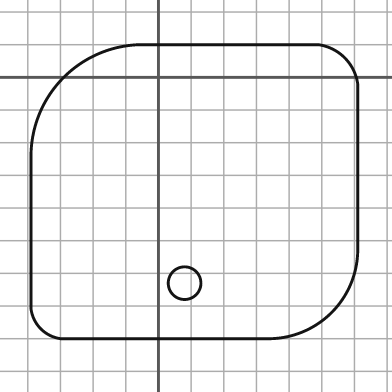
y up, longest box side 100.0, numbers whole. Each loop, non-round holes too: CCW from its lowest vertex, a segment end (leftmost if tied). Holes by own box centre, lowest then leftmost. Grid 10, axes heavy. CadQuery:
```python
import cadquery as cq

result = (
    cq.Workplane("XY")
    .moveTo(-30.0, -80.0)
    .lineTo(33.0, -80.0)
    .threePointArc((53.0, -72.0), (61.0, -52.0))
    .lineTo(61.0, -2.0)
    .threePointArc((57.0, 6.0), (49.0, 10.0))
    .lineTo(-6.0, 10.0)
    .threePointArc((-29.0, 0.0), (-39.0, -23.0))
    .lineTo(-39.0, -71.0)
    .threePointArc((-36.0, -77.0), (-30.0, -80.0))
    .close()
    .moveTo(8.0, -63.0)
    .circle(5.0)
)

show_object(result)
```